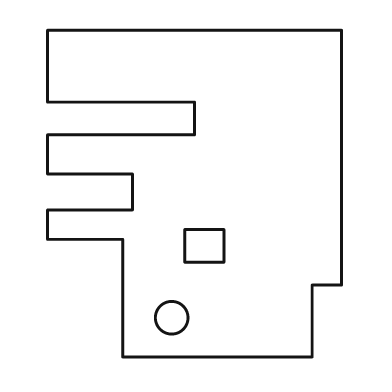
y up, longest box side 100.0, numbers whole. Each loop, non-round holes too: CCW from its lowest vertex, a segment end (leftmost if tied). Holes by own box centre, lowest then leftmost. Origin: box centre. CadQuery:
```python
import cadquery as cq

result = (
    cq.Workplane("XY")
    .moveTo(-22.0, -50.0)
    .lineTo(36.0, -50.0)
    .lineTo(36.0, -28.0)
    .lineTo(45.0, -28.0)
    .lineTo(45.0, 50.0)
    .lineTo(-45.0, 50.0)
    .lineTo(-45.0, 28.0)
    .lineTo(0.0, 28.0)
    .lineTo(0.0, 18.0)
    .lineTo(-45.0, 18.0)
    .lineTo(-45.0, 6.0)
    .lineTo(-19.0, 6.0)
    .lineTo(-19.0, -5.0)
    .lineTo(-45.0, -5.0)
    .lineTo(-45.0, -14.0)
    .lineTo(-22.0, -14.0)
    .close()
    .moveTo(-7.0, -38.0)
    .circle(5.0)
    .moveTo(-3.0, -21.0)
    .lineTo(9.0, -21.0)
    .lineTo(9.0, -11.0)
    .lineTo(-3.0, -11.0)
    .close()
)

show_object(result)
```